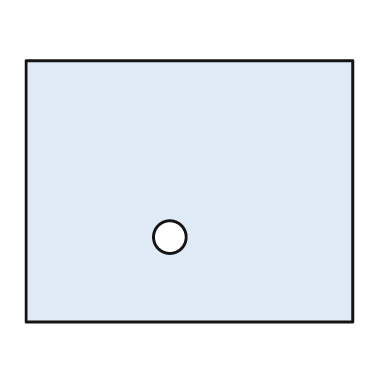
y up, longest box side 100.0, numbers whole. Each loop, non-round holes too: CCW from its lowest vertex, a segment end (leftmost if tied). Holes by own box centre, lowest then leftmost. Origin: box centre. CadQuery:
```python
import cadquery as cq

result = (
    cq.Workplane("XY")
    .moveTo(-50.0, -40.0)
    .lineTo(50.0, -40.0)
    .lineTo(50.0, 40.0)
    .lineTo(-50.0, 40.0)
    .close()
    .moveTo(-6.0, -14.0)
    .circle(5.0)
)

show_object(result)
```